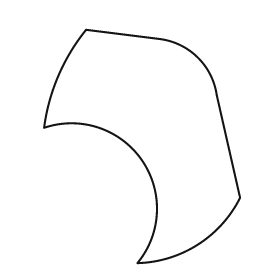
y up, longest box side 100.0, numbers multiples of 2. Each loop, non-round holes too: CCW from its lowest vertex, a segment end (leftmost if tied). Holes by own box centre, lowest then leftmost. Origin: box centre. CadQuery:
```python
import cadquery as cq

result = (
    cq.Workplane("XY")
    .moveTo(-2.0, -50.0)
    .threePointArc((24.0, -42.0), (42.0, -22.0))
    .lineTo(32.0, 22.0)
    .threePointArc((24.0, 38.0), (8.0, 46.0))
    .lineTo(-24.0, 50.0)
    .threePointArc((-36.0, 30.0), (-42.0, 8.0))
    .threePointArc((0.0, -6.0), (-2.0, -50.0))
    .close()
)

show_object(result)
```